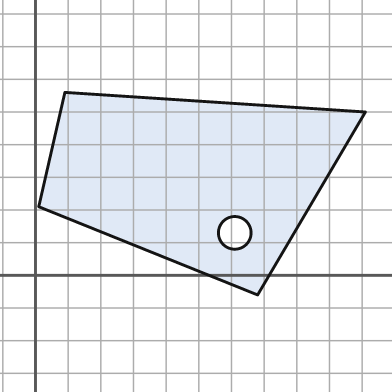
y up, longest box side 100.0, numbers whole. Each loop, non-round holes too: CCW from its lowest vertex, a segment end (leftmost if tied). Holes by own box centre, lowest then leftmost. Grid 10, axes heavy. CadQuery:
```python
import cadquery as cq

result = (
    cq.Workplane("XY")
    .moveTo(68.0, -6.0)
    .lineTo(101.0, 50.0)
    .lineTo(9.0, 56.0)
    .lineTo(1.0, 21.0)
    .close()
    .moveTo(61.0, 13.0)
    .circle(5.0)
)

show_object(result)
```